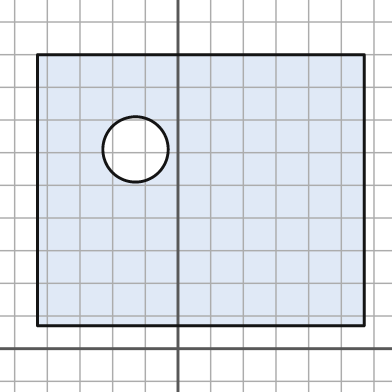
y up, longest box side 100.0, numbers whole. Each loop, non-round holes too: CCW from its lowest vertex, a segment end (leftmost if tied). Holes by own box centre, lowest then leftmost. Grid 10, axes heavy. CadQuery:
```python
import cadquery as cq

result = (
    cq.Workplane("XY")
    .moveTo(-43.0, 7.0)
    .lineTo(57.0, 7.0)
    .lineTo(57.0, 90.0)
    .lineTo(-43.0, 90.0)
    .close()
    .moveTo(-13.0, 61.0)
    .circle(10.0)
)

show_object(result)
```